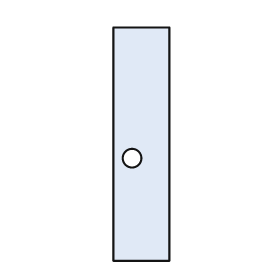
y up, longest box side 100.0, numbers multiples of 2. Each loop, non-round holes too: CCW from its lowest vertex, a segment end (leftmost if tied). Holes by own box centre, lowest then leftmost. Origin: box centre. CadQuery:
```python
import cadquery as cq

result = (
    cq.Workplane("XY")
    .moveTo(-12.0, -50.0)
    .lineTo(12.0, -50.0)
    .lineTo(12.0, 50.0)
    .lineTo(-12.0, 50.0)
    .close()
    .moveTo(-4.0, -6.0)
    .circle(4.0)
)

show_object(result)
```